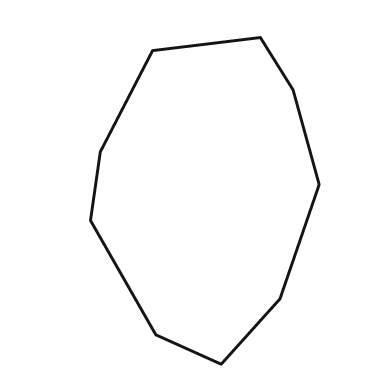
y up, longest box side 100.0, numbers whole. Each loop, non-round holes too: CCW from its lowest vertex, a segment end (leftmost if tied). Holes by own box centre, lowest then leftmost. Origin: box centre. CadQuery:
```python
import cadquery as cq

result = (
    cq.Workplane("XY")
    .moveTo(5.0, -50.0)
    .lineTo(23.0, -30.0)
    .lineTo(35.0, 5.0)
    .lineTo(27.0, 34.0)
    .lineTo(17.0, 50.0)
    .lineTo(-16.0, 46.0)
    .lineTo(-32.0, 15.0)
    .lineTo(-35.0, -6.0)
    .lineTo(-15.0, -41.0)
    .close()
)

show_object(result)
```